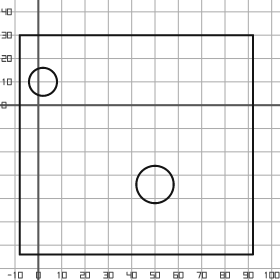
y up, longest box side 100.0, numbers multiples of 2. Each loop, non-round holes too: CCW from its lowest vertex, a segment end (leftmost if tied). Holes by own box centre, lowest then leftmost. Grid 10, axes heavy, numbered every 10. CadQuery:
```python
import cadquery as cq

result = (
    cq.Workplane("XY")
    .moveTo(-8.0, -64.0)
    .lineTo(92.0, -64.0)
    .lineTo(92.0, 30.0)
    .lineTo(-8.0, 30.0)
    .close()
    .moveTo(50.0, -34.0)
    .circle(8.0)
    .moveTo(2.0, 10.0)
    .circle(6.0)
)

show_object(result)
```